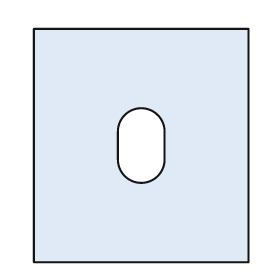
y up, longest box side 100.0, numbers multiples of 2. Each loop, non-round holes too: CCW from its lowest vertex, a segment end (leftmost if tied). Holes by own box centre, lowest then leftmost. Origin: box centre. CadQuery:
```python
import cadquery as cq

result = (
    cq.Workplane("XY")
    .moveTo(-46.0, -50.0)
    .lineTo(46.0, -50.0)
    .lineTo(46.0, 50.0)
    .lineTo(-46.0, 50.0)
    .close()
    .moveTo(-10.0, -6.0)
    .threePointArc((0.0, -16.0), (10.0, -6.0))
    .lineTo(10.0, 6.0)
    .threePointArc((0.0, 16.0), (-10.0, 6.0))
    .close()
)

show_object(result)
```